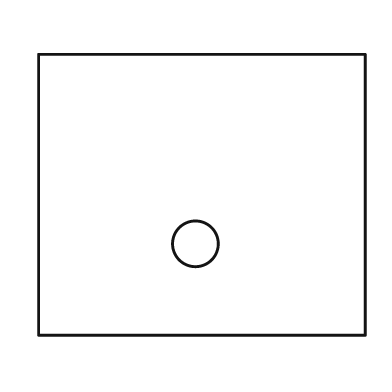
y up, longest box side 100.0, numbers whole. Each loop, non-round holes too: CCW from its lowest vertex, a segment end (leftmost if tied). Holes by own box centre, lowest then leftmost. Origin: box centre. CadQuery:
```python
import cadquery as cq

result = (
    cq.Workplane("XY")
    .moveTo(-50.0, -43.0)
    .lineTo(50.0, -43.0)
    .lineTo(50.0, 43.0)
    .lineTo(-50.0, 43.0)
    .close()
    .moveTo(-2.0, -15.0)
    .circle(7.0)
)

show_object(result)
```